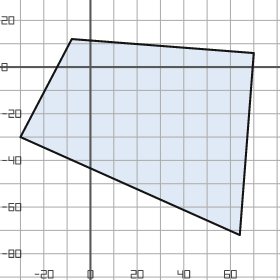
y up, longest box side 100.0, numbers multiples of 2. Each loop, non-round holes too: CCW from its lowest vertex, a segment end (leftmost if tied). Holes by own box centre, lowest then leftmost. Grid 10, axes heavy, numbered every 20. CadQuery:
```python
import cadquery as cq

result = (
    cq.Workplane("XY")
    .moveTo(64.0, -72.0)
    .lineTo(70.0, 6.0)
    .lineTo(-8.0, 12.0)
    .lineTo(-30.0, -30.0)
    .close()
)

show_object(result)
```